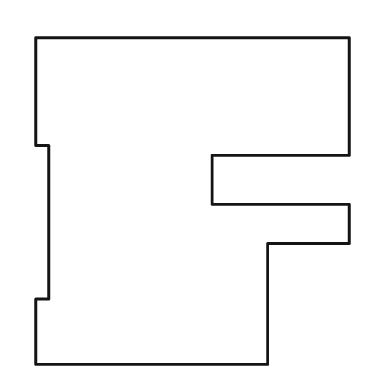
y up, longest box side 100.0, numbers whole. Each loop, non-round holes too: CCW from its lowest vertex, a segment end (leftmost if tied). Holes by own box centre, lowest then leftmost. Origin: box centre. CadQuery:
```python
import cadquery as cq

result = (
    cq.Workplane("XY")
    .moveTo(-48.0, -50.0)
    .lineTo(23.0, -50.0)
    .lineTo(23.0, -13.0)
    .lineTo(48.0, -13.0)
    .lineTo(48.0, -1.0)
    .lineTo(6.0, -1.0)
    .lineTo(6.0, 14.0)
    .lineTo(48.0, 14.0)
    .lineTo(48.0, 50.0)
    .lineTo(-48.0, 50.0)
    .lineTo(-48.0, 17.0)
    .lineTo(-44.0, 17.0)
    .lineTo(-44.0, -30.0)
    .lineTo(-48.0, -30.0)
    .close()
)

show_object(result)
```